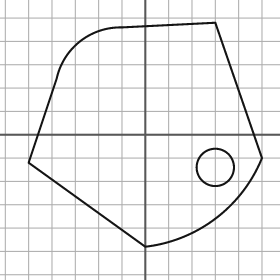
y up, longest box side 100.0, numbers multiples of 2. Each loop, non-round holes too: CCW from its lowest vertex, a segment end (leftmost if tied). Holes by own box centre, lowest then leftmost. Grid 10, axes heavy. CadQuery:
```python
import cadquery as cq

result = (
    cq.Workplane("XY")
    .moveTo(0.0, -48.0)
    .threePointArc((30.0, -36.0), (50.0, -10.0))
    .lineTo(30.0, 48.0)
    .lineTo(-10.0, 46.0)
    .threePointArc((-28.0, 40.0), (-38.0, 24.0))
    .lineTo(-50.0, -12.0)
    .close()
    .moveTo(30.0, -14.0)
    .circle(8.0)
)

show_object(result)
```